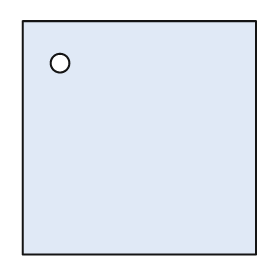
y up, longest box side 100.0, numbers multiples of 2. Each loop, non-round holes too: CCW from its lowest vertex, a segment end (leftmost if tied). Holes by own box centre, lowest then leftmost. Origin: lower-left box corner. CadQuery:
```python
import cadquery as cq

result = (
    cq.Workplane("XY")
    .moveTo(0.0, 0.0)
    .lineTo(100.0, 0.0)
    .lineTo(100.0, 100.0)
    .lineTo(0.0, 100.0)
    .close()
    .moveTo(16.0, 82.0)
    .circle(4.0)
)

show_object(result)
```